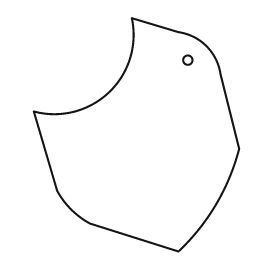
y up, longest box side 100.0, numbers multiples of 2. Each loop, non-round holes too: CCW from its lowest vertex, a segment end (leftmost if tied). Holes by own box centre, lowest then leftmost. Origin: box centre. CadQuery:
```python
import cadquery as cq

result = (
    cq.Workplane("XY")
    .moveTo(18.0, -50.0)
    .threePointArc((34.0, -30.0), (44.0, -6.0))
    .lineTo(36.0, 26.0)
    .threePointArc((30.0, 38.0), (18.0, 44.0))
    .lineTo(-2.0, 50.0)
    .threePointArc((-12.0, 18.0), (-44.0, 10.0))
    .lineTo(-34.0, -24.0)
    .threePointArc((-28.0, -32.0), (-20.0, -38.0))
    .close()
    .moveTo(22.0, 32.0)
    .circle(2.0)
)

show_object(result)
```